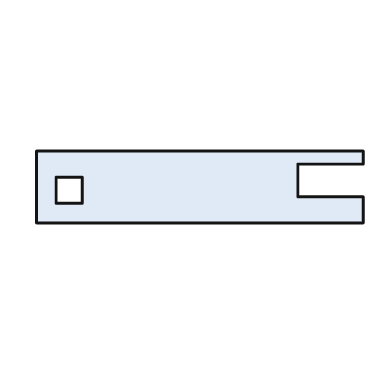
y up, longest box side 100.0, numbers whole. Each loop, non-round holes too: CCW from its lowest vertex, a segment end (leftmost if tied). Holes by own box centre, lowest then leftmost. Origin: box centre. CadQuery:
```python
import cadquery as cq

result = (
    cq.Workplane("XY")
    .moveTo(-50.0, -11.0)
    .lineTo(50.0, -11.0)
    .lineTo(50.0, -3.0)
    .lineTo(30.0, -3.0)
    .lineTo(30.0, 7.0)
    .lineTo(50.0, 7.0)
    .lineTo(50.0, 11.0)
    .lineTo(-50.0, 11.0)
    .close()
    .moveTo(-44.0, -5.0)
    .lineTo(-36.0, -5.0)
    .lineTo(-36.0, 3.0)
    .lineTo(-44.0, 3.0)
    .close()
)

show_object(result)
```